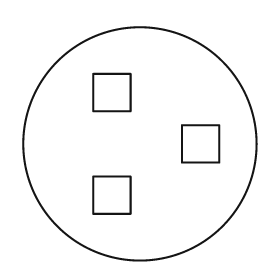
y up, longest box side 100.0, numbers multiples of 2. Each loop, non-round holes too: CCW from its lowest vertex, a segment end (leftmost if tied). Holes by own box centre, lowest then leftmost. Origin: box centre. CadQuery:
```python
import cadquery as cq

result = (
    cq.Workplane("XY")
    .moveTo(0.0, 0.0)
    .circle(50.0)
    .moveTo(-20.0, -30.0)
    .lineTo(-4.0, -30.0)
    .lineTo(-4.0, -14.0)
    .lineTo(-20.0, -14.0)
    .close()
    .moveTo(18.0, -8.0)
    .lineTo(34.0, -8.0)
    .lineTo(34.0, 8.0)
    .lineTo(18.0, 8.0)
    .close()
    .moveTo(-20.0, 14.0)
    .lineTo(-4.0, 14.0)
    .lineTo(-4.0, 30.0)
    .lineTo(-20.0, 30.0)
    .close()
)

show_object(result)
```